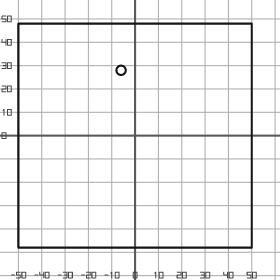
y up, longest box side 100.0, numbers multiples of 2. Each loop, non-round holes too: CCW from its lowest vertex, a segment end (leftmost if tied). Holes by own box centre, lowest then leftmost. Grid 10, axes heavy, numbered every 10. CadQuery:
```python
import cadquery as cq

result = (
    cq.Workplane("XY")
    .moveTo(-50.0, -48.0)
    .lineTo(50.0, -48.0)
    .lineTo(50.0, 48.0)
    .lineTo(-50.0, 48.0)
    .close()
    .moveTo(-6.0, 28.0)
    .circle(2.0)
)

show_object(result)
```